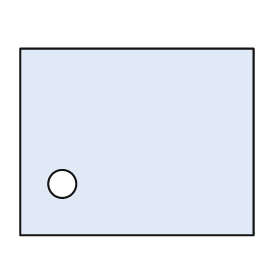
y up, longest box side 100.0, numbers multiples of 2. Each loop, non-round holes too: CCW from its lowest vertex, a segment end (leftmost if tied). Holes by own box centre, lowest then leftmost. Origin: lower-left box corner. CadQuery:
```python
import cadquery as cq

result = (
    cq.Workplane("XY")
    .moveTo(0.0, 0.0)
    .lineTo(100.0, 0.0)
    .lineTo(100.0, 80.0)
    .lineTo(0.0, 80.0)
    .close()
    .moveTo(18.0, 22.0)
    .circle(6.0)
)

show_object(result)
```